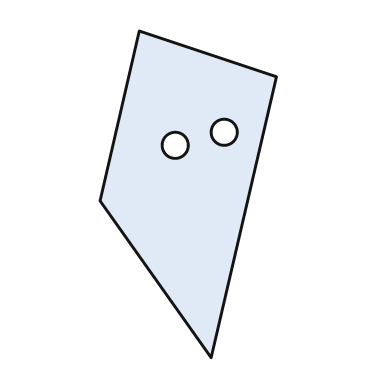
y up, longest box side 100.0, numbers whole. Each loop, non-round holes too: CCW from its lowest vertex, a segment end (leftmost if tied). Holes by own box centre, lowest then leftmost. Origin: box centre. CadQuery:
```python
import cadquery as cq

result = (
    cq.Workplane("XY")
    .moveTo(7.0, -50.0)
    .lineTo(27.0, 36.0)
    .lineTo(-15.0, 50.0)
    .lineTo(-27.0, -2.0)
    .close()
    .moveTo(-4.0, 15.0)
    .circle(4.0)
    .moveTo(11.0, 19.0)
    .circle(4.0)
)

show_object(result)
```